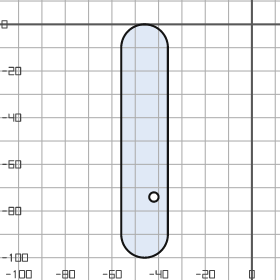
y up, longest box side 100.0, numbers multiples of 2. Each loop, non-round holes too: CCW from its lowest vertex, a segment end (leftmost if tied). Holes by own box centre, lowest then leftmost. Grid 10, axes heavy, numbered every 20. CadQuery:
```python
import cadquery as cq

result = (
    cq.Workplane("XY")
    .moveTo(-56.0, -90.0)
    .threePointArc((-46.0, -100.0), (-36.0, -90.0))
    .lineTo(-36.0, -10.0)
    .threePointArc((-46.0, 0.0), (-56.0, -10.0))
    .close()
    .moveTo(-42.0, -74.0)
    .circle(2.0)
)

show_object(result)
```